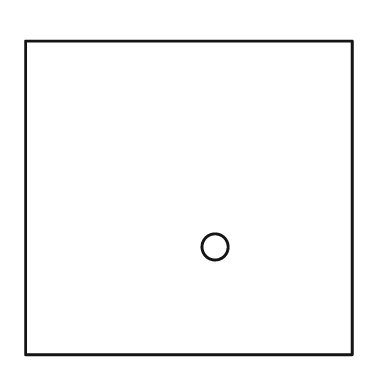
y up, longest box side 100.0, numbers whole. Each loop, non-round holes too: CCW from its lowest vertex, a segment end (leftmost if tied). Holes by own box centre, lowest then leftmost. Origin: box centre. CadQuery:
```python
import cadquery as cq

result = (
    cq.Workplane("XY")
    .moveTo(-50.0, -48.0)
    .lineTo(50.0, -48.0)
    .lineTo(50.0, 48.0)
    .lineTo(-50.0, 48.0)
    .close()
    .moveTo(8.0, -15.0)
    .circle(4.0)
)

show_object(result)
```